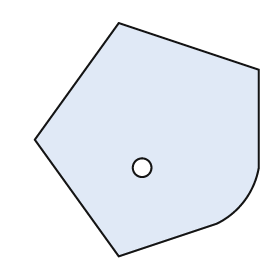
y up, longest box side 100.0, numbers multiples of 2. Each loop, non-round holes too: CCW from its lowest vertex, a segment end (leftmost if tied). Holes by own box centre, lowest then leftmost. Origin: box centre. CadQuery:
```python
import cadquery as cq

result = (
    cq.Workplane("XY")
    .moveTo(-12.0, -50.0)
    .lineTo(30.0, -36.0)
    .threePointArc((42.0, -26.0), (48.0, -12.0))
    .lineTo(48.0, 30.0)
    .lineTo(-12.0, 50.0)
    .lineTo(-48.0, 0.0)
    .close()
    .moveTo(-2.0, -12.0)
    .circle(4.0)
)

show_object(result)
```